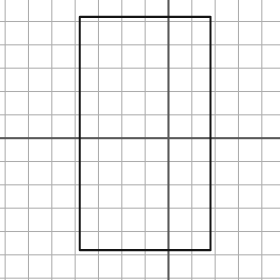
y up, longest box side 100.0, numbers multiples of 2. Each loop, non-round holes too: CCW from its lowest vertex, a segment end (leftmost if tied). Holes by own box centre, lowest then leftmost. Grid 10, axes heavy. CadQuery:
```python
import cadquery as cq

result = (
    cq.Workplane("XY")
    .moveTo(-38.0, -48.0)
    .lineTo(18.0, -48.0)
    .lineTo(18.0, 52.0)
    .lineTo(-38.0, 52.0)
    .close()
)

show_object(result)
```